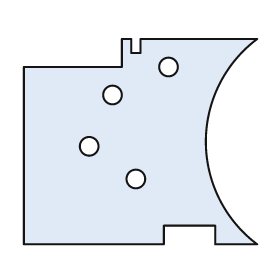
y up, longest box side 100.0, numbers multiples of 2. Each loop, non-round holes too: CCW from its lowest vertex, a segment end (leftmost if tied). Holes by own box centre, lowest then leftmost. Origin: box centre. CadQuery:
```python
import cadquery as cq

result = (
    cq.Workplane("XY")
    .moveTo(-50.0, -44.0)
    .lineTo(10.0, -44.0)
    .lineTo(10.0, -36.0)
    .lineTo(32.0, -36.0)
    .lineTo(32.0, -44.0)
    .lineTo(50.0, -44.0)
    .threePointArc((28.0, 0.0), (50.0, 44.0))
    .lineTo(0.0, 44.0)
    .lineTo(0.0, 38.0)
    .lineTo(-4.0, 38.0)
    .lineTo(-4.0, 44.0)
    .lineTo(-8.0, 44.0)
    .lineTo(-8.0, 32.0)
    .lineTo(-50.0, 32.0)
    .close()
    .moveTo(-2.0, -16.0)
    .circle(4.0)
    .moveTo(-22.0, -2.0)
    .circle(4.0)
    .moveTo(-12.0, 20.0)
    .circle(4.0)
    .moveTo(12.0, 32.0)
    .circle(4.0)
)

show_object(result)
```